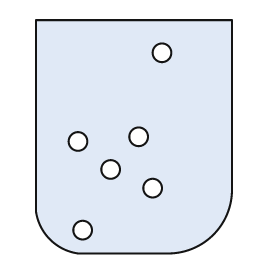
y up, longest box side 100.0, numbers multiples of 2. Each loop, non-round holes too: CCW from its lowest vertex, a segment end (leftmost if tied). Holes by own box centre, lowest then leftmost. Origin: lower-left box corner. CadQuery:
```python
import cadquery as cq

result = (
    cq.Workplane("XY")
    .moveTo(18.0, 0.0)
    .lineTo(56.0, 0.0)
    .threePointArc((76.0, 8.0), (84.0, 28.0))
    .lineTo(84.0, 100.0)
    .lineTo(0.0, 100.0)
    .lineTo(0.0, 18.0)
    .threePointArc((6.0, 6.0), (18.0, 0.0))
    .close()
    .moveTo(20.0, 10.0)
    .circle(4.0)
    .moveTo(50.0, 28.0)
    .circle(4.0)
    .moveTo(32.0, 36.0)
    .circle(4.0)
    .moveTo(18.0, 48.0)
    .circle(4.0)
    .moveTo(44.0, 50.0)
    .circle(4.0)
    .moveTo(54.0, 86.0)
    .circle(4.0)
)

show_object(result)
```